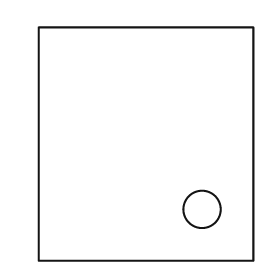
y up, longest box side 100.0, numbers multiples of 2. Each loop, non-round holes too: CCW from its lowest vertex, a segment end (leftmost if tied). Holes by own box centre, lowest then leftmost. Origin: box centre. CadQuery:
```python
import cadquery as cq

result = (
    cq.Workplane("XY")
    .moveTo(-46.0, -50.0)
    .lineTo(46.0, -50.0)
    .lineTo(46.0, 50.0)
    .lineTo(-46.0, 50.0)
    .close()
    .moveTo(24.0, -28.0)
    .circle(8.0)
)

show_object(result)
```